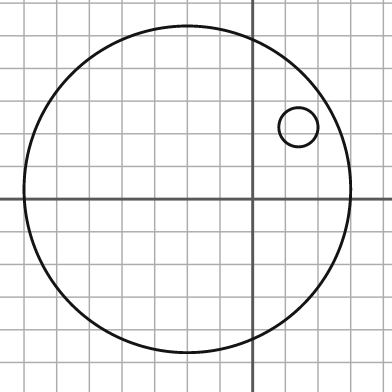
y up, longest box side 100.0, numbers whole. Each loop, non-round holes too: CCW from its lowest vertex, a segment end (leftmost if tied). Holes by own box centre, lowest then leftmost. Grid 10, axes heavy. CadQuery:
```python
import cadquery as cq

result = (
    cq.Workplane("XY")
    .moveTo(-20.0, 3.0)
    .circle(50.0)
    .moveTo(14.0, 22.0)
    .circle(6.0)
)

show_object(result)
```